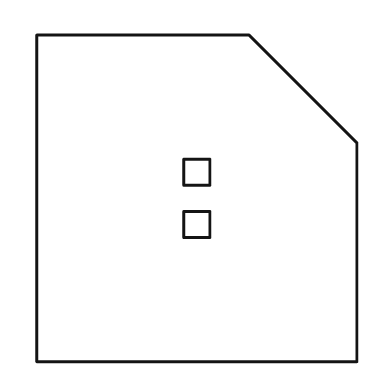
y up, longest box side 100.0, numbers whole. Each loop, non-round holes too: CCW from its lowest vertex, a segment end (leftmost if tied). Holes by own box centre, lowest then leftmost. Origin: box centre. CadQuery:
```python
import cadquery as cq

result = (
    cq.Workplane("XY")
    .moveTo(-49.0, -50.0)
    .lineTo(49.0, -50.0)
    .lineTo(49.0, 17.0)
    .lineTo(16.0, 50.0)
    .lineTo(-49.0, 50.0)
    .close()
    .moveTo(-4.0, -12.0)
    .lineTo(4.0, -12.0)
    .lineTo(4.0, -4.0)
    .lineTo(-4.0, -4.0)
    .close()
    .moveTo(-4.0, 4.0)
    .lineTo(4.0, 4.0)
    .lineTo(4.0, 12.0)
    .lineTo(-4.0, 12.0)
    .close()
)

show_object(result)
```